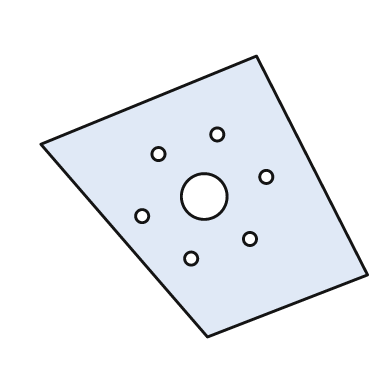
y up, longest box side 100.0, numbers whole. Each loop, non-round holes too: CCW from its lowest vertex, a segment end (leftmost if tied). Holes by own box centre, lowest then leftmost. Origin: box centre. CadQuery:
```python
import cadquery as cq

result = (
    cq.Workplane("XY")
    .moveTo(1.0, -43.0)
    .lineTo(50.0, -24.0)
    .lineTo(16.0, 43.0)
    .lineTo(-50.0, 16.0)
    .close()
    .moveTo(-4.0, -19.0)
    .circle(2.0)
    .moveTo(14.0, -13.0)
    .circle(2.0)
    .moveTo(-19.0, -6.0)
    .circle(2.0)
    .moveTo(0.0, 0.0)
    .circle(7.0)
    .moveTo(19.0, 6.0)
    .circle(2.0)
    .moveTo(-14.0, 13.0)
    .circle(2.0)
    .moveTo(4.0, 19.0)
    .circle(2.0)
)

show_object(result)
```